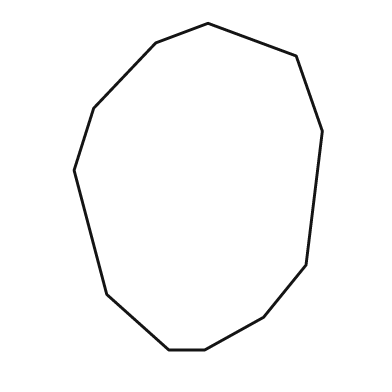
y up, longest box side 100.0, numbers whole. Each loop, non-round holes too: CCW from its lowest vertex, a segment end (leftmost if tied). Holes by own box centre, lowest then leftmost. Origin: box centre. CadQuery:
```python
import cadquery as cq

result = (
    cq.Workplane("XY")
    .moveTo(-9.0, -50.0)
    .lineTo(2.0, -50.0)
    .lineTo(20.0, -40.0)
    .lineTo(33.0, -24.0)
    .lineTo(38.0, 17.0)
    .lineTo(30.0, 40.0)
    .lineTo(3.0, 50.0)
    .lineTo(-13.0, 44.0)
    .lineTo(-32.0, 24.0)
    .lineTo(-38.0, 5.0)
    .lineTo(-28.0, -33.0)
    .close()
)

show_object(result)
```